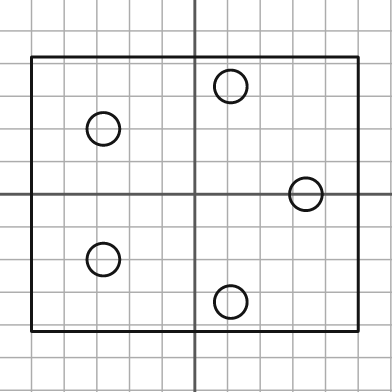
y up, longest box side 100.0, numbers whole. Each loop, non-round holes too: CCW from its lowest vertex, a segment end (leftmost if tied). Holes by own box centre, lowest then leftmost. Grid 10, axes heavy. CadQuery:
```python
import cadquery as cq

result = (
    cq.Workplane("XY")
    .moveTo(-50.0, -42.0)
    .lineTo(50.0, -42.0)
    .lineTo(50.0, 42.0)
    .lineTo(-50.0, 42.0)
    .close()
    .moveTo(11.0, -33.0)
    .circle(5.0)
    .moveTo(-28.0, -20.0)
    .circle(5.0)
    .moveTo(34.0, 0.0)
    .circle(5.0)
    .moveTo(-28.0, 20.0)
    .circle(5.0)
    .moveTo(11.0, 33.0)
    .circle(5.0)
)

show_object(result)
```